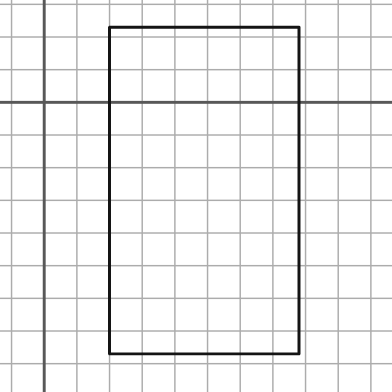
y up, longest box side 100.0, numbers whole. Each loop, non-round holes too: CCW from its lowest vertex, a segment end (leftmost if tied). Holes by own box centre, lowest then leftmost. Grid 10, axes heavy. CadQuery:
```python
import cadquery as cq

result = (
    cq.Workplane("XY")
    .moveTo(20.0, -77.0)
    .lineTo(78.0, -77.0)
    .lineTo(78.0, 23.0)
    .lineTo(20.0, 23.0)
    .close()
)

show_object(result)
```